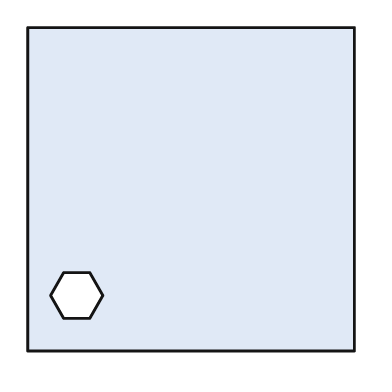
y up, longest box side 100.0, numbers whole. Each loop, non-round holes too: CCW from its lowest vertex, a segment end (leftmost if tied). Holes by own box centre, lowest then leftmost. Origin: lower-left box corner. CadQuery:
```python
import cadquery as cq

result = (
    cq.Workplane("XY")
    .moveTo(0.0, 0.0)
    .lineTo(100.0, 0.0)
    .lineTo(100.0, 99.0)
    .lineTo(0.0, 99.0)
    .close()
    .moveTo(11.0, 10.0)
    .lineTo(19.0, 10.0)
    .lineTo(23.0, 17.0)
    .lineTo(19.0, 24.0)
    .lineTo(11.0, 24.0)
    .lineTo(7.0, 17.0)
    .close()
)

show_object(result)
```